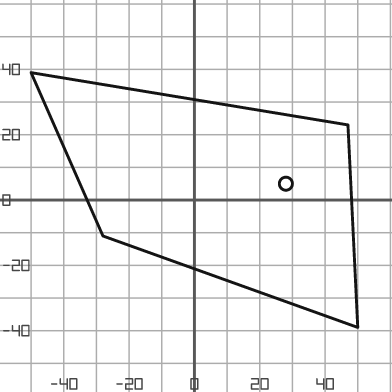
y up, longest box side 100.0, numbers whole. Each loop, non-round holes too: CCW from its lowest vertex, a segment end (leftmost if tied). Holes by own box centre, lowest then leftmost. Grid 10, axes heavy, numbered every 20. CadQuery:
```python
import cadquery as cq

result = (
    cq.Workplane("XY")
    .moveTo(50.0, -39.0)
    .lineTo(47.0, 23.0)
    .lineTo(-50.0, 39.0)
    .lineTo(-28.0, -11.0)
    .close()
    .moveTo(28.0, 5.0)
    .circle(2.0)
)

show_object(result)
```